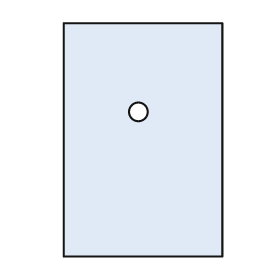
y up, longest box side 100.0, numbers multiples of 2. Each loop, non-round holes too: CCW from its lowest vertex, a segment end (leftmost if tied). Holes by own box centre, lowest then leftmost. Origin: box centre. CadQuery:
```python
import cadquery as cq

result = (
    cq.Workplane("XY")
    .moveTo(-34.0, -50.0)
    .lineTo(34.0, -50.0)
    .lineTo(34.0, 50.0)
    .lineTo(-34.0, 50.0)
    .close()
    .moveTo(-2.0, 12.0)
    .circle(4.0)
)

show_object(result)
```